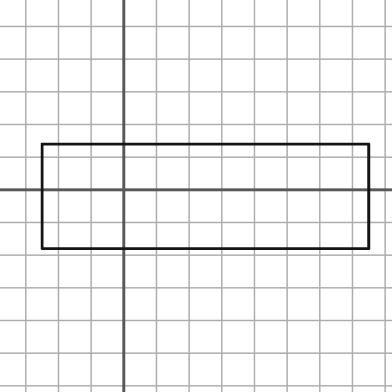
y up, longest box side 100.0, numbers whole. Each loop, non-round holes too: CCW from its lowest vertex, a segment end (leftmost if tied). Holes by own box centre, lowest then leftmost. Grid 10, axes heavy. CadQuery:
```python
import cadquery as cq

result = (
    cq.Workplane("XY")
    .moveTo(-25.0, -18.0)
    .lineTo(75.0, -18.0)
    .lineTo(75.0, 14.0)
    .lineTo(-25.0, 14.0)
    .close()
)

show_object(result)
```